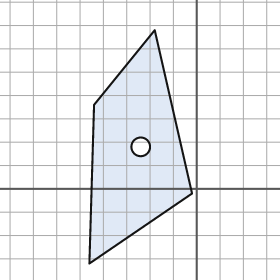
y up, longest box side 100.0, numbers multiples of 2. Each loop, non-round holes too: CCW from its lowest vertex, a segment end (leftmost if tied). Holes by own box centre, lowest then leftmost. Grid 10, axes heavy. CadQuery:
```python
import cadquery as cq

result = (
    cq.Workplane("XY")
    .moveTo(-46.0, -32.0)
    .lineTo(-2.0, -2.0)
    .lineTo(-18.0, 68.0)
    .lineTo(-44.0, 36.0)
    .close()
    .moveTo(-24.0, 18.0)
    .circle(4.0)
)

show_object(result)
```